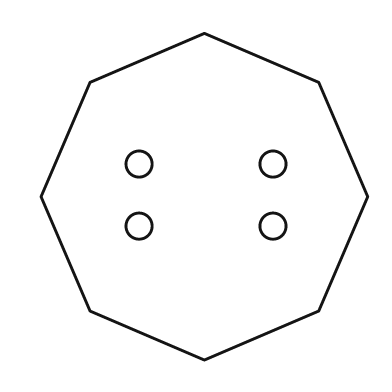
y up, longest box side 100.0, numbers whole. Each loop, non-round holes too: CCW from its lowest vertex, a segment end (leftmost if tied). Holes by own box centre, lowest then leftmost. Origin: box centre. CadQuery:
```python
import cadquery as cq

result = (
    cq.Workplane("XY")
    .moveTo(0.0, -50.0)
    .lineTo(35.0, -35.0)
    .lineTo(50.0, 0.0)
    .lineTo(35.0, 35.0)
    .lineTo(0.0, 50.0)
    .lineTo(-35.0, 35.0)
    .lineTo(-50.0, 0.0)
    .lineTo(-35.0, -35.0)
    .close()
    .moveTo(-20.0, -9.0)
    .circle(4.0)
    .moveTo(21.0, -9.0)
    .circle(4.0)
    .moveTo(-20.0, 10.0)
    .circle(4.0)
    .moveTo(21.0, 10.0)
    .circle(4.0)
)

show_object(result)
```